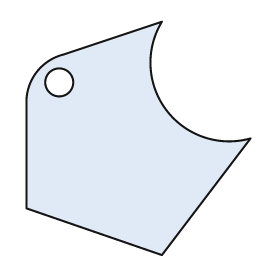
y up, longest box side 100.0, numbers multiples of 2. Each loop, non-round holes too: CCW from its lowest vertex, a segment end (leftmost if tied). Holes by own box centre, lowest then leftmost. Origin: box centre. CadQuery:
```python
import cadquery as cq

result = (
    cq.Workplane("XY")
    .moveTo(10.0, -50.0)
    .lineTo(48.0, 0.0)
    .threePointArc((12.0, 12.0), (10.0, 50.0))
    .lineTo(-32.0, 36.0)
    .threePointArc((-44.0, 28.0), (-48.0, 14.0))
    .lineTo(-48.0, -30.0)
    .close()
    .moveTo(-34.0, 24.0)
    .circle(6.0)
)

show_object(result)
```